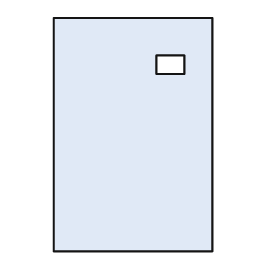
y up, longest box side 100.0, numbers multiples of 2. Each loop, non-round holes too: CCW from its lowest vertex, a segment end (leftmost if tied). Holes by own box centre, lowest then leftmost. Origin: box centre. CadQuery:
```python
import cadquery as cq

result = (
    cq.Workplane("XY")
    .moveTo(-34.0, -50.0)
    .lineTo(34.0, -50.0)
    .lineTo(34.0, 50.0)
    .lineTo(-34.0, 50.0)
    .close()
    .moveTo(10.0, 26.0)
    .lineTo(22.0, 26.0)
    .lineTo(22.0, 34.0)
    .lineTo(10.0, 34.0)
    .close()
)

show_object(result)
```